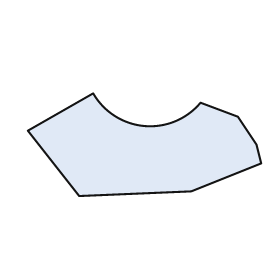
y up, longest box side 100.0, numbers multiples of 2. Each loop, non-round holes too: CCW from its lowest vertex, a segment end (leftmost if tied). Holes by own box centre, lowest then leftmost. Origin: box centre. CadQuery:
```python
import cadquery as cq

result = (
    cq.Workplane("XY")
    .moveTo(-28.0, -22.0)
    .lineTo(20.0, -20.0)
    .lineTo(50.0, -8.0)
    .lineTo(48.0, 0.0)
    .lineTo(40.0, 12.0)
    .lineTo(24.0, 18.0)
    .threePointArc((0.0, 8.0), (-22.0, 22.0))
    .lineTo(-50.0, 6.0)
    .close()
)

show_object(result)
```